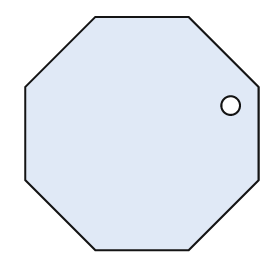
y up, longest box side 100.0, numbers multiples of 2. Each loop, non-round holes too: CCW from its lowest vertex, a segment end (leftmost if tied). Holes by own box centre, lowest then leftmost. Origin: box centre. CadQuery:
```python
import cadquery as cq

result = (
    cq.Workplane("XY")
    .moveTo(-20.0, -50.0)
    .lineTo(20.0, -50.0)
    .lineTo(50.0, -20.0)
    .lineTo(50.0, 20.0)
    .lineTo(20.0, 50.0)
    .lineTo(-20.0, 50.0)
    .lineTo(-50.0, 20.0)
    .lineTo(-50.0, -20.0)
    .close()
    .moveTo(38.0, 12.0)
    .circle(4.0)
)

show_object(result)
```